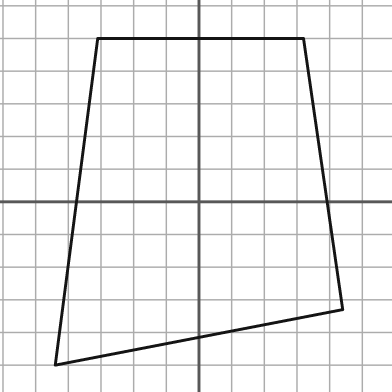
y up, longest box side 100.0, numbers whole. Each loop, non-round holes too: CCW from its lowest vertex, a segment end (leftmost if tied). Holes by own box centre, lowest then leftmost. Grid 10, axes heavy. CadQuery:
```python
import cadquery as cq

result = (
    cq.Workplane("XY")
    .moveTo(-44.0, -50.0)
    .lineTo(44.0, -33.0)
    .lineTo(32.0, 50.0)
    .lineTo(-31.0, 50.0)
    .close()
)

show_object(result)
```